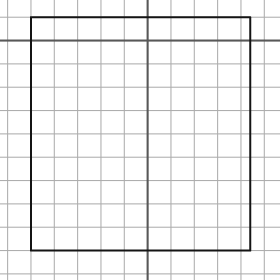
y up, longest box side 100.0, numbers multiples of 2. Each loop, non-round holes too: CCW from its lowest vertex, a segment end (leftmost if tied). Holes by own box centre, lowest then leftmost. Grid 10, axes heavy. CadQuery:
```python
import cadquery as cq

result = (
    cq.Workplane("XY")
    .moveTo(-50.0, -90.0)
    .lineTo(44.0, -90.0)
    .lineTo(44.0, 10.0)
    .lineTo(-50.0, 10.0)
    .close()
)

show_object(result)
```